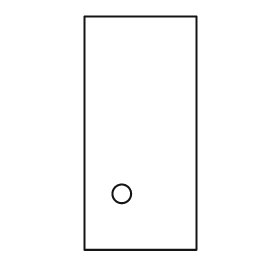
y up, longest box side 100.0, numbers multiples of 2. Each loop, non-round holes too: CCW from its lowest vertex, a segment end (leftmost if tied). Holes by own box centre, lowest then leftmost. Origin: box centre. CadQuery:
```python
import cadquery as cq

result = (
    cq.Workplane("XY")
    .moveTo(-24.0, -50.0)
    .lineTo(24.0, -50.0)
    .lineTo(24.0, 50.0)
    .lineTo(-24.0, 50.0)
    .close()
    .moveTo(-8.0, -26.0)
    .circle(4.0)
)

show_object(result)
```